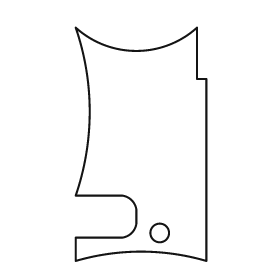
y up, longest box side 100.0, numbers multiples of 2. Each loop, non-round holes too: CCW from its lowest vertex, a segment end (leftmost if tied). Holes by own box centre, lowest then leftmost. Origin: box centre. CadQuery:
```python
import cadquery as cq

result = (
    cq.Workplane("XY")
    .moveTo(-28.0, -50.0)
    .threePointArc((0.0, -46.0), (28.0, -50.0))
    .lineTo(28.0, 28.0)
    .lineTo(24.0, 28.0)
    .lineTo(24.0, 50.0)
    .threePointArc((-2.0, 40.0), (-28.0, 50.0))
    .threePointArc((-22.0, 14.0), (-28.0, -22.0))
    .lineTo(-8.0, -22.0)
    .threePointArc((-4.0, -24.0), (-2.0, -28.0))
    .lineTo(-2.0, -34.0)
    .threePointArc((-4.0, -38.0), (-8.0, -40.0))
    .lineTo(-28.0, -40.0)
    .close()
    .moveTo(8.0, -38.0)
    .circle(4.0)
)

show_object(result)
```